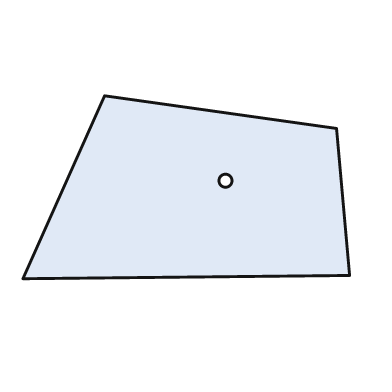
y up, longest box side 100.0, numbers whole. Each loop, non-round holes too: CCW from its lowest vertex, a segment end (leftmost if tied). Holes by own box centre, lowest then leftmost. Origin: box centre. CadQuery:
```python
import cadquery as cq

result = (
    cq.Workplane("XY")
    .moveTo(-50.0, -28.0)
    .lineTo(50.0, -27.0)
    .lineTo(46.0, 18.0)
    .lineTo(-25.0, 28.0)
    .close()
    .moveTo(12.0, 2.0)
    .circle(2.0)
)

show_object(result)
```